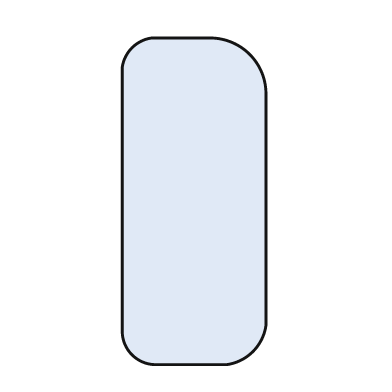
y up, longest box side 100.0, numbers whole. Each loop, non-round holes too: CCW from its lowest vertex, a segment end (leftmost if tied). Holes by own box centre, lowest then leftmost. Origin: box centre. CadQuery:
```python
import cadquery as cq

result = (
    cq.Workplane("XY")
    .moveTo(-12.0, -50.0)
    .lineTo(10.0, -50.0)
    .threePointArc((18.0, -46.0), (22.0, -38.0))
    .lineTo(22.0, 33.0)
    .threePointArc((17.0, 45.0), (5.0, 50.0))
    .lineTo(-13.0, 50.0)
    .threePointArc((-19.0, 47.0), (-22.0, 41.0))
    .lineTo(-22.0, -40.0)
    .threePointArc((-19.0, -47.0), (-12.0, -50.0))
    .close()
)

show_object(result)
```